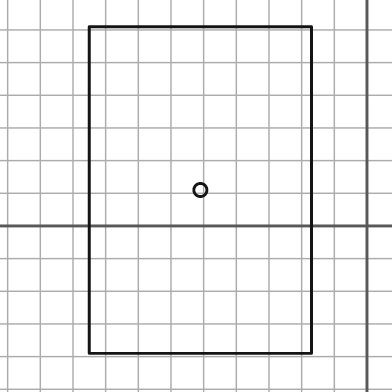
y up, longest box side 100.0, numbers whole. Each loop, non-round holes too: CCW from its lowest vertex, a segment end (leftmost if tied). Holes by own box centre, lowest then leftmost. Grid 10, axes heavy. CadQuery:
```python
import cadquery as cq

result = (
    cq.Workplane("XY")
    .moveTo(-85.0, -39.0)
    .lineTo(-17.0, -39.0)
    .lineTo(-17.0, 61.0)
    .lineTo(-85.0, 61.0)
    .close()
    .moveTo(-51.0, 11.0)
    .circle(2.0)
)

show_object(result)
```